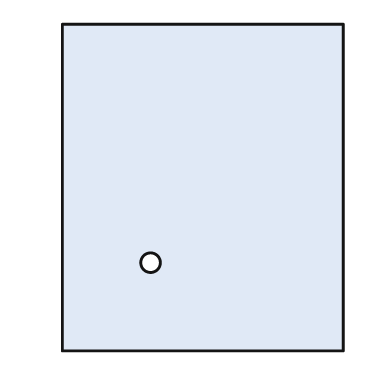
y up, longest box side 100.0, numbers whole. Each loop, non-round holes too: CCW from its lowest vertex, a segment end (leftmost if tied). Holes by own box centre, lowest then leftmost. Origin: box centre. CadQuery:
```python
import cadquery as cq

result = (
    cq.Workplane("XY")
    .moveTo(-43.0, -50.0)
    .lineTo(43.0, -50.0)
    .lineTo(43.0, 50.0)
    .lineTo(-43.0, 50.0)
    .close()
    .moveTo(-16.0, -23.0)
    .circle(3.0)
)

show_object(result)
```